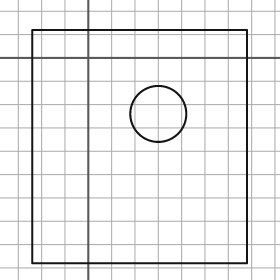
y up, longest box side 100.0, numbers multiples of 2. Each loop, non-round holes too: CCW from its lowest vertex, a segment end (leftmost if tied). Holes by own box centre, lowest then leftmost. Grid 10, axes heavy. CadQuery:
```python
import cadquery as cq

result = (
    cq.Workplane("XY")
    .moveTo(-24.0, -88.0)
    .lineTo(68.0, -88.0)
    .lineTo(68.0, 12.0)
    .lineTo(-24.0, 12.0)
    .close()
    .moveTo(30.0, -24.0)
    .circle(12.0)
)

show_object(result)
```